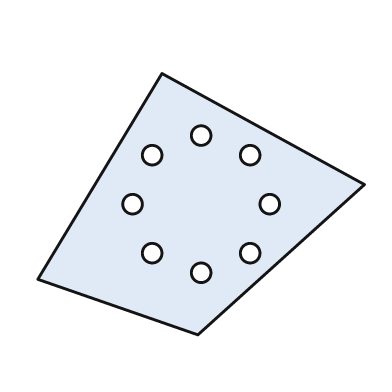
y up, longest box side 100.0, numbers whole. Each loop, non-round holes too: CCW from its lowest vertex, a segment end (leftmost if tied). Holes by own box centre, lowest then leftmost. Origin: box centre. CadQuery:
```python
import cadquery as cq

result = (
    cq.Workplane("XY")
    .moveTo(-1.0, -40.0)
    .lineTo(50.0, 6.0)
    .lineTo(-12.0, 40.0)
    .lineTo(-50.0, -23.0)
    .close()
    .moveTo(0.0, -21.0)
    .circle(3.0)
    .moveTo(-15.0, -15.0)
    .circle(3.0)
    .moveTo(15.0, -15.0)
    .circle(3.0)
    .moveTo(-21.0, 0.0)
    .circle(3.0)
    .moveTo(21.0, 0.0)
    .circle(3.0)
    .moveTo(-15.0, 15.0)
    .circle(3.0)
    .moveTo(15.0, 15.0)
    .circle(3.0)
    .moveTo(0.0, 21.0)
    .circle(3.0)
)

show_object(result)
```